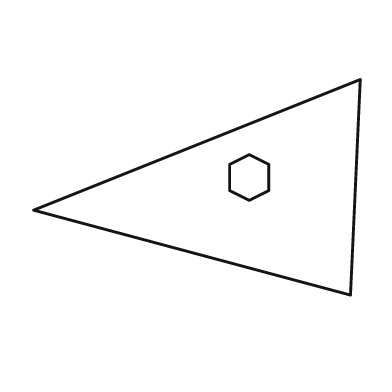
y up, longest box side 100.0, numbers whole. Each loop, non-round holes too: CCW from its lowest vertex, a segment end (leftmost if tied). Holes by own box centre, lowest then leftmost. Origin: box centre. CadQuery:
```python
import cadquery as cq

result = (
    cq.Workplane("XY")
    .moveTo(47.0, -33.0)
    .lineTo(50.0, 33.0)
    .lineTo(-50.0, -7.0)
    .close()
    .moveTo(16.0, -4.0)
    .lineTo(22.0, -1.0)
    .lineTo(22.0, 7.0)
    .lineTo(16.0, 10.0)
    .lineTo(10.0, 7.0)
    .lineTo(10.0, -1.0)
    .close()
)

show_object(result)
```